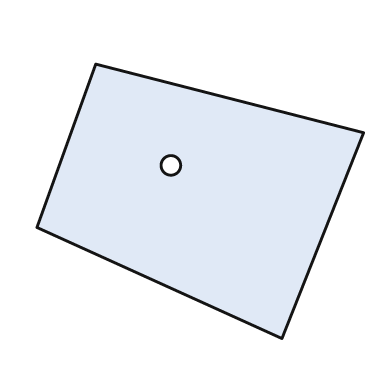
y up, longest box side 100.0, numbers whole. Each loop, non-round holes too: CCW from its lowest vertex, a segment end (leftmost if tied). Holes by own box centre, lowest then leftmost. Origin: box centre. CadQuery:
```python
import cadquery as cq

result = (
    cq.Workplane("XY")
    .moveTo(25.0, -42.0)
    .lineTo(50.0, 21.0)
    .lineTo(-32.0, 42.0)
    .lineTo(-50.0, -8.0)
    .close()
    .moveTo(-9.0, 11.0)
    .circle(3.0)
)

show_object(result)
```